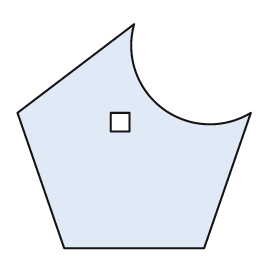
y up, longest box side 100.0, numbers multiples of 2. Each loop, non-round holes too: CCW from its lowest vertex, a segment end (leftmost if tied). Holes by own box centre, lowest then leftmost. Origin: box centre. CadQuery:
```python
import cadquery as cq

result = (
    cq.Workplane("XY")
    .moveTo(-30.0, -48.0)
    .lineTo(30.0, -48.0)
    .lineTo(50.0, 10.0)
    .threePointArc((12.0, 12.0), (0.0, 48.0))
    .lineTo(-50.0, 10.0)
    .close()
    .moveTo(-10.0, 2.0)
    .lineTo(-2.0, 2.0)
    .lineTo(-2.0, 10.0)
    .lineTo(-10.0, 10.0)
    .close()
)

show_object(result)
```